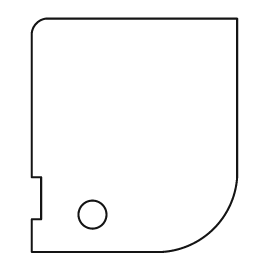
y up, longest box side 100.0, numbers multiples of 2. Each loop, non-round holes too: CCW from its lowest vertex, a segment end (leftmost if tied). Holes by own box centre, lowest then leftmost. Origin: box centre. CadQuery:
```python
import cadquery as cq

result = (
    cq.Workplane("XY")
    .moveTo(-44.0, -50.0)
    .lineTo(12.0, -50.0)
    .threePointArc((34.0, -40.0), (44.0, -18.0))
    .lineTo(44.0, 50.0)
    .lineTo(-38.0, 50.0)
    .threePointArc((-42.0, 48.0), (-44.0, 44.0))
    .lineTo(-44.0, -18.0)
    .lineTo(-40.0, -18.0)
    .lineTo(-40.0, -36.0)
    .lineTo(-44.0, -36.0)
    .close()
    .moveTo(-18.0, -34.0)
    .circle(6.0)
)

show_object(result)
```